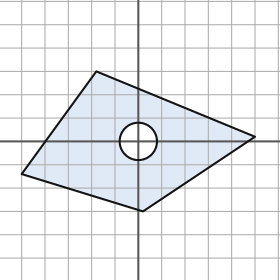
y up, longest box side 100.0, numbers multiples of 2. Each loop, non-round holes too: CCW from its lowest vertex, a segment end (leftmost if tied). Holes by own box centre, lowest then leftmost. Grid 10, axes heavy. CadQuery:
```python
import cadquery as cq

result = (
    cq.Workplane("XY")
    .moveTo(2.0, -30.0)
    .lineTo(50.0, 2.0)
    .lineTo(-18.0, 30.0)
    .lineTo(-50.0, -14.0)
    .close()
    .moveTo(0.0, 0.0)
    .circle(8.0)
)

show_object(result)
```